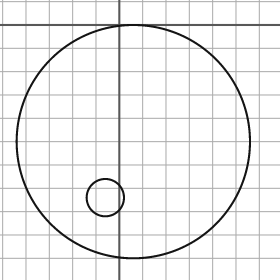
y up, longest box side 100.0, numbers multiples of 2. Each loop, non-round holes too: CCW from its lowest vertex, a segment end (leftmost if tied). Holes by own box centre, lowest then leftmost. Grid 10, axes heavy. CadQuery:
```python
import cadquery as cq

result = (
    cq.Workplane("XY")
    .moveTo(6.0, -50.0)
    .circle(50.0)
    .moveTo(-6.0, -74.0)
    .circle(8.0)
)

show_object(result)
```